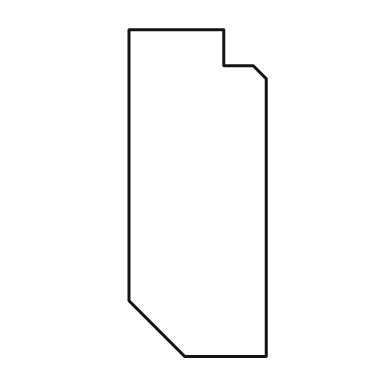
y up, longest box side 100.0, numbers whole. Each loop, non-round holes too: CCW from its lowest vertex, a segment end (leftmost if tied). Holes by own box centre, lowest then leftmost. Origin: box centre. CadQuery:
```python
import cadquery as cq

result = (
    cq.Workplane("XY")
    .moveTo(-4.0, -50.0)
    .lineTo(21.0, -50.0)
    .lineTo(21.0, 35.0)
    .lineTo(17.0, 39.0)
    .lineTo(8.0, 39.0)
    .lineTo(8.0, 50.0)
    .lineTo(-21.0, 50.0)
    .lineTo(-21.0, -33.0)
    .close()
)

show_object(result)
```